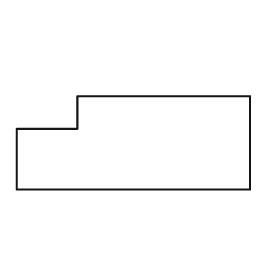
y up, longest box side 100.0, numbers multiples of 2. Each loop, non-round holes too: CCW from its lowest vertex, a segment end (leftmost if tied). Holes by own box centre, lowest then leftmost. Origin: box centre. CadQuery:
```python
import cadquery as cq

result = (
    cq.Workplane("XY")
    .moveTo(-50.0, -20.0)
    .lineTo(50.0, -20.0)
    .lineTo(50.0, 20.0)
    .lineTo(-24.0, 20.0)
    .lineTo(-24.0, 6.0)
    .lineTo(-50.0, 6.0)
    .close()
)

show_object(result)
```